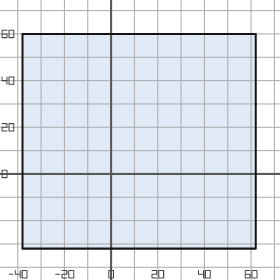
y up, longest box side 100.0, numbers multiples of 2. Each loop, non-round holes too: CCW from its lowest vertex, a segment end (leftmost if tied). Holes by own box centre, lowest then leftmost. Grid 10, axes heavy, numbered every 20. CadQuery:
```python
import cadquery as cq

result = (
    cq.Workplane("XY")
    .moveTo(-38.0, -32.0)
    .lineTo(62.0, -32.0)
    .lineTo(62.0, 60.0)
    .lineTo(-38.0, 60.0)
    .close()
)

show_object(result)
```